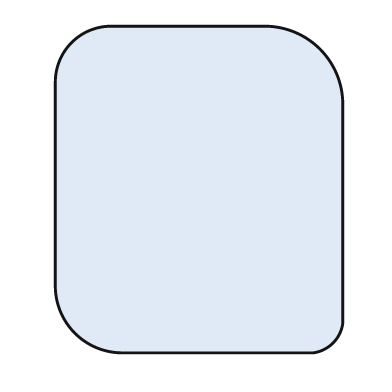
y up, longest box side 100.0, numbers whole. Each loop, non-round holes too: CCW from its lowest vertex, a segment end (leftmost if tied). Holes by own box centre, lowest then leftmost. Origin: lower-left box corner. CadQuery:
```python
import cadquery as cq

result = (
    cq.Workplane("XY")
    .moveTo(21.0, 0.0)
    .lineTo(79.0, 0.0)
    .threePointArc((85.0, 3.0), (88.0, 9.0))
    .lineTo(88.0, 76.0)
    .threePointArc((81.0, 93.0), (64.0, 100.0))
    .lineTo(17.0, 100.0)
    .threePointArc((5.0, 95.0), (0.0, 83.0))
    .lineTo(0.0, 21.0)
    .threePointArc((6.0, 6.0), (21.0, 0.0))
    .close()
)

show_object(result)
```